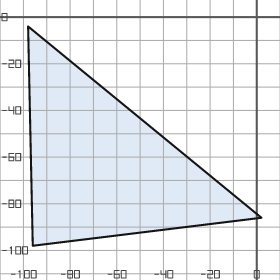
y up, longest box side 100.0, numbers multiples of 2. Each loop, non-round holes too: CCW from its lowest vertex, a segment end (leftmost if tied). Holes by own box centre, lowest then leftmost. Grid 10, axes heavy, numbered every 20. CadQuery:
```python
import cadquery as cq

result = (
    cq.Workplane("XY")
    .moveTo(-96.0, -98.0)
    .lineTo(2.0, -86.0)
    .lineTo(-98.0, -4.0)
    .close()
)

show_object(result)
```